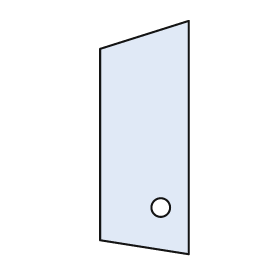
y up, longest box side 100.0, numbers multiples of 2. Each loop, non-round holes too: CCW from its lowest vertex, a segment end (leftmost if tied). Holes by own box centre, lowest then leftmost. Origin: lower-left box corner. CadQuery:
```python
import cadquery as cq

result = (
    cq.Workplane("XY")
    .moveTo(38.0, 0.0)
    .lineTo(38.0, 100.0)
    .lineTo(0.0, 88.0)
    .lineTo(0.0, 6.0)
    .close()
    .moveTo(26.0, 20.0)
    .circle(4.0)
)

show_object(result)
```